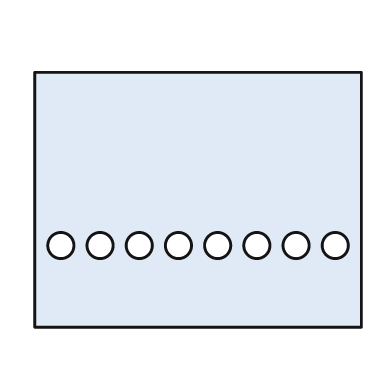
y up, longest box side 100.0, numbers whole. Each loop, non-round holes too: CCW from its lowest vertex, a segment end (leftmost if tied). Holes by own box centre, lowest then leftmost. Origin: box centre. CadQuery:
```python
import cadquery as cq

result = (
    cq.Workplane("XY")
    .moveTo(-50.0, -39.0)
    .lineTo(50.0, -39.0)
    .lineTo(50.0, 39.0)
    .lineTo(-50.0, 39.0)
    .close()
    .moveTo(-42.0, -14.0)
    .circle(4.0)
    .moveTo(-30.0, -14.0)
    .circle(4.0)
    .moveTo(-18.0, -14.0)
    .circle(4.0)
    .moveTo(-6.0, -14.0)
    .circle(4.0)
    .moveTo(6.0, -14.0)
    .circle(4.0)
    .moveTo(18.0, -14.0)
    .circle(4.0)
    .moveTo(30.0, -14.0)
    .circle(4.0)
    .moveTo(42.0, -14.0)
    .circle(4.0)
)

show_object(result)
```